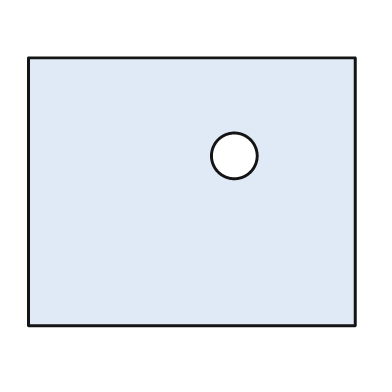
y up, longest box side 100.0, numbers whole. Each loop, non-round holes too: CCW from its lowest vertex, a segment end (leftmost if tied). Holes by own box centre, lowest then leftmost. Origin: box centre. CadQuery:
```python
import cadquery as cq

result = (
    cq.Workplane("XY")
    .moveTo(-50.0, -41.0)
    .lineTo(50.0, -41.0)
    .lineTo(50.0, 41.0)
    .lineTo(-50.0, 41.0)
    .close()
    .moveTo(13.0, 11.0)
    .circle(7.0)
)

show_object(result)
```